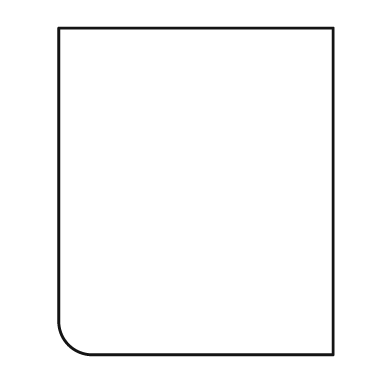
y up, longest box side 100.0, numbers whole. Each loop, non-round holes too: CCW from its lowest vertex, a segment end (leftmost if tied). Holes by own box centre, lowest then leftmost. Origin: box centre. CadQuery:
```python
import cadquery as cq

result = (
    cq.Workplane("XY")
    .moveTo(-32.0, -50.0)
    .lineTo(42.0, -50.0)
    .lineTo(42.0, 50.0)
    .lineTo(-42.0, 50.0)
    .lineTo(-42.0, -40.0)
    .threePointArc((-39.0, -47.0), (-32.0, -50.0))
    .close()
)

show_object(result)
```